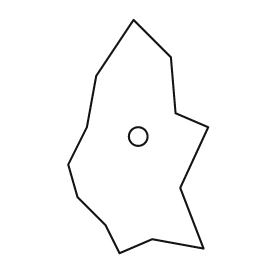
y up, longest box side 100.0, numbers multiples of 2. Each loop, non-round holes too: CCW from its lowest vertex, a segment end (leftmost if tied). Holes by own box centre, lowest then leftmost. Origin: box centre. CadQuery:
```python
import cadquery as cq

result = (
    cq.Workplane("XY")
    .moveTo(-8.0, -50.0)
    .lineTo(6.0, -44.0)
    .lineTo(28.0, -48.0)
    .lineTo(18.0, -22.0)
    .lineTo(30.0, 4.0)
    .lineTo(16.0, 10.0)
    .lineTo(14.0, 34.0)
    .lineTo(-2.0, 50.0)
    .lineTo(-18.0, 26.0)
    .lineTo(-22.0, 4.0)
    .lineTo(-30.0, -12.0)
    .lineTo(-26.0, -26.0)
    .lineTo(-14.0, -38.0)
    .close()
    .moveTo(0.0, 0.0)
    .circle(4.0)
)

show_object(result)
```